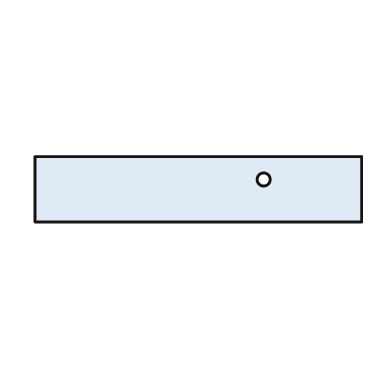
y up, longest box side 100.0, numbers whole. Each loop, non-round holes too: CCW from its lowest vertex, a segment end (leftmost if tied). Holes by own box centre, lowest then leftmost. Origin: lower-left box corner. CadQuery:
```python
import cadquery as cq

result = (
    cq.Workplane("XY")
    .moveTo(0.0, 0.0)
    .lineTo(100.0, 0.0)
    .lineTo(100.0, 20.0)
    .lineTo(0.0, 20.0)
    .close()
    .moveTo(70.0, 13.0)
    .circle(2.0)
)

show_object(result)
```